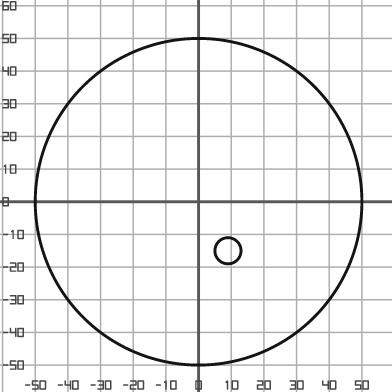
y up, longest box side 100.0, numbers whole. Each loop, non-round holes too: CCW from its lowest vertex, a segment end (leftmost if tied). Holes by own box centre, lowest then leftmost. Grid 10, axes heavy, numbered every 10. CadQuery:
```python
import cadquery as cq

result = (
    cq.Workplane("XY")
    .moveTo(0.0, 0.0)
    .circle(50.0)
    .moveTo(9.0, -15.0)
    .circle(4.0)
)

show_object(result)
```